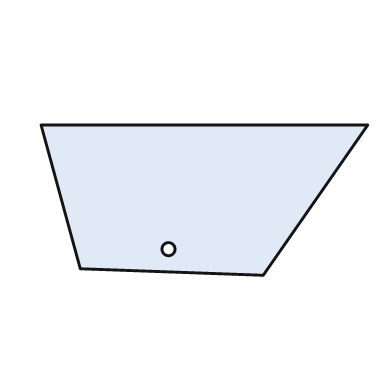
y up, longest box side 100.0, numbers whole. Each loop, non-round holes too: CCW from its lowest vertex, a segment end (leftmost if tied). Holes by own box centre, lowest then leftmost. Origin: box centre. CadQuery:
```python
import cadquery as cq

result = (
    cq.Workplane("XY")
    .moveTo(18.0, -23.0)
    .lineTo(50.0, 23.0)
    .lineTo(-50.0, 23.0)
    .lineTo(-38.0, -21.0)
    .close()
    .moveTo(-11.0, -15.0)
    .circle(2.0)
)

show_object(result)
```